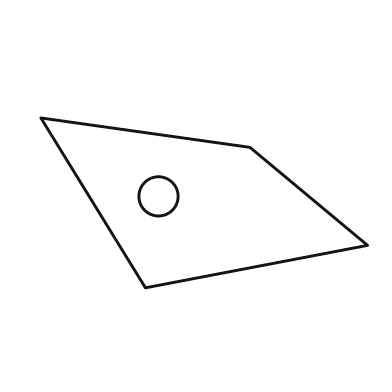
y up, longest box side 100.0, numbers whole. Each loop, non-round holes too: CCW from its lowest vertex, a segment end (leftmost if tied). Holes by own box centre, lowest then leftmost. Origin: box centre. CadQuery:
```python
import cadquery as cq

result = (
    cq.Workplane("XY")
    .moveTo(-18.0, -26.0)
    .lineTo(50.0, -13.0)
    .lineTo(14.0, 17.0)
    .lineTo(-50.0, 26.0)
    .close()
    .moveTo(-14.0, 2.0)
    .circle(6.0)
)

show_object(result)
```